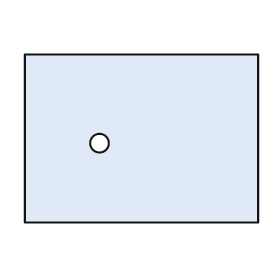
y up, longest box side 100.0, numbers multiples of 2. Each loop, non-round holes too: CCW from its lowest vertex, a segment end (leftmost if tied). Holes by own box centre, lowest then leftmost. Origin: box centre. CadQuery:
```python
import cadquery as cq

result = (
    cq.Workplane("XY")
    .moveTo(-50.0, -36.0)
    .lineTo(50.0, -36.0)
    .lineTo(50.0, 36.0)
    .lineTo(-50.0, 36.0)
    .close()
    .moveTo(-18.0, -2.0)
    .circle(4.0)
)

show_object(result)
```